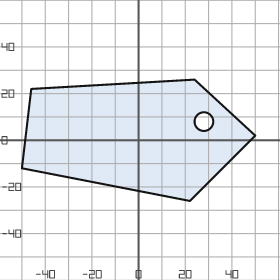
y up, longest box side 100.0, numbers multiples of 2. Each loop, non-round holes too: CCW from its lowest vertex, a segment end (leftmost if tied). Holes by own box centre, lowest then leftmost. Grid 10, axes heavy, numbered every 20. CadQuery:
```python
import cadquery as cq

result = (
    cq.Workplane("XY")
    .moveTo(22.0, -26.0)
    .lineTo(50.0, 2.0)
    .lineTo(24.0, 26.0)
    .lineTo(-46.0, 22.0)
    .lineTo(-50.0, -12.0)
    .close()
    .moveTo(28.0, 8.0)
    .circle(4.0)
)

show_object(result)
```